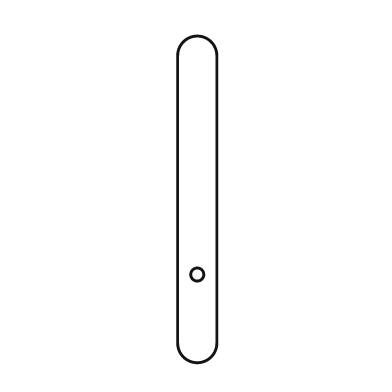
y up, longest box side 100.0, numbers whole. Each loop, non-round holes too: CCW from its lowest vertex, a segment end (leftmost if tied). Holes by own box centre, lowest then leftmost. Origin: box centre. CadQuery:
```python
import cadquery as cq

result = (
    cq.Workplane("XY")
    .moveTo(-6.0, -44.0)
    .threePointArc((0.0, -50.0), (6.0, -44.0))
    .lineTo(6.0, 44.0)
    .threePointArc((0.0, 50.0), (-6.0, 44.0))
    .close()
    .moveTo(0.0, -23.0)
    .circle(2.0)
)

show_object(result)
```